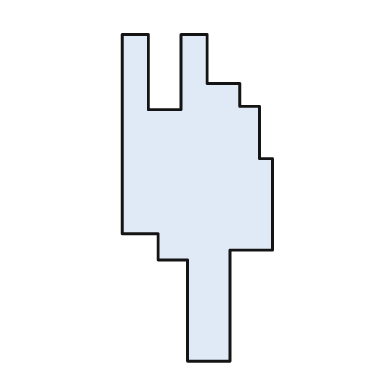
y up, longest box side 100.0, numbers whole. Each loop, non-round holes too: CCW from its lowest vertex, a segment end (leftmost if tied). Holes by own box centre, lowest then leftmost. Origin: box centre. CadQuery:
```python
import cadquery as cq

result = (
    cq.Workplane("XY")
    .moveTo(-3.0, -50.0)
    .lineTo(10.0, -50.0)
    .lineTo(10.0, -16.0)
    .lineTo(23.0, -16.0)
    .lineTo(23.0, 12.0)
    .lineTo(19.0, 12.0)
    .lineTo(19.0, 28.0)
    .lineTo(13.0, 28.0)
    .lineTo(13.0, 35.0)
    .lineTo(3.0, 35.0)
    .lineTo(3.0, 50.0)
    .lineTo(-5.0, 50.0)
    .lineTo(-5.0, 27.0)
    .lineTo(-15.0, 27.0)
    .lineTo(-15.0, 50.0)
    .lineTo(-23.0, 50.0)
    .lineTo(-23.0, -11.0)
    .lineTo(-12.0, -11.0)
    .lineTo(-12.0, -19.0)
    .lineTo(-3.0, -19.0)
    .close()
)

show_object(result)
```